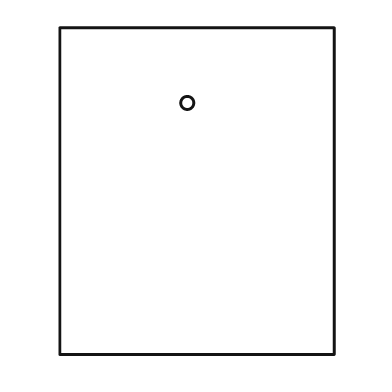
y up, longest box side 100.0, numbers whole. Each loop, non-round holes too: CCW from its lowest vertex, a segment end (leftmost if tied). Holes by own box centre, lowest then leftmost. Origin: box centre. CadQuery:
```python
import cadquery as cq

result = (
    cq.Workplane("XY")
    .moveTo(-42.0, -50.0)
    .lineTo(42.0, -50.0)
    .lineTo(42.0, 50.0)
    .lineTo(-42.0, 50.0)
    .close()
    .moveTo(-3.0, 27.0)
    .circle(2.0)
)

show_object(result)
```